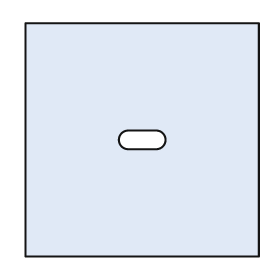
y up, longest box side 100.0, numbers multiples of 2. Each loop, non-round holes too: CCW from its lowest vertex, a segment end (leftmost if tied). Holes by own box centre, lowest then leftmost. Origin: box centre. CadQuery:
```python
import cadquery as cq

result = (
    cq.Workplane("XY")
    .moveTo(-50.0, -50.0)
    .lineTo(50.0, -50.0)
    .lineTo(50.0, 50.0)
    .lineTo(-50.0, 50.0)
    .close()
    .moveTo(-6.0, -4.0)
    .lineTo(6.0, -4.0)
    .threePointArc((10.0, 0.0), (6.0, 4.0))
    .lineTo(-6.0, 4.0)
    .threePointArc((-10.0, 0.0), (-6.0, -4.0))
    .close()
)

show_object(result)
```